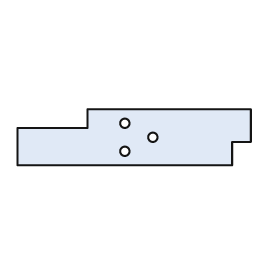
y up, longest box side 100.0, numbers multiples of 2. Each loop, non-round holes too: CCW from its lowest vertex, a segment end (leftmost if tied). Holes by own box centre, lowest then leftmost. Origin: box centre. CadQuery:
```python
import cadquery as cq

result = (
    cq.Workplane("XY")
    .moveTo(-50.0, -12.0)
    .lineTo(42.0, -12.0)
    .lineTo(42.0, -2.0)
    .lineTo(50.0, -2.0)
    .lineTo(50.0, 12.0)
    .lineTo(-20.0, 12.0)
    .lineTo(-20.0, 4.0)
    .lineTo(-50.0, 4.0)
    .close()
    .moveTo(-4.0, -6.0)
    .circle(2.0)
    .moveTo(8.0, 0.0)
    .circle(2.0)
    .moveTo(-4.0, 6.0)
    .circle(2.0)
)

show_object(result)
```